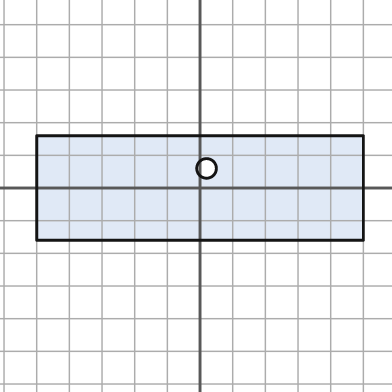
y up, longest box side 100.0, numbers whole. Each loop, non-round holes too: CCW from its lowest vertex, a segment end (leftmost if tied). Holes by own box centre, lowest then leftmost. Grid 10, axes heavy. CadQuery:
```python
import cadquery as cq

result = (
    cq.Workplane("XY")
    .moveTo(-50.0, -16.0)
    .lineTo(50.0, -16.0)
    .lineTo(50.0, 16.0)
    .lineTo(-50.0, 16.0)
    .close()
    .moveTo(2.0, 6.0)
    .circle(3.0)
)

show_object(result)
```